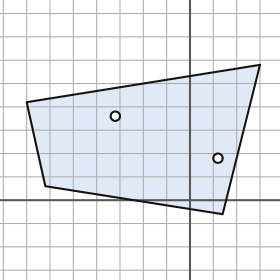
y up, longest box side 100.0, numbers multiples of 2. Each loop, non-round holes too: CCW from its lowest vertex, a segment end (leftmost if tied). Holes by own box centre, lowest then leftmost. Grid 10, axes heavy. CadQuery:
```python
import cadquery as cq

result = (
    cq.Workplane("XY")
    .moveTo(14.0, -6.0)
    .lineTo(30.0, 58.0)
    .lineTo(-70.0, 42.0)
    .lineTo(-62.0, 6.0)
    .close()
    .moveTo(12.0, 18.0)
    .circle(2.0)
    .moveTo(-32.0, 36.0)
    .circle(2.0)
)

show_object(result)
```